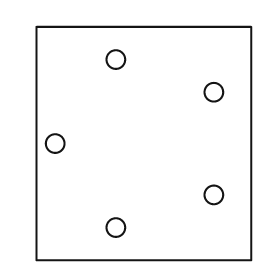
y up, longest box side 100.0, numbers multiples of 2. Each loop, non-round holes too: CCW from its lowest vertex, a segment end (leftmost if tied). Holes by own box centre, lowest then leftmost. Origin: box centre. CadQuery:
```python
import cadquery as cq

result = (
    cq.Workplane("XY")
    .moveTo(-46.0, -50.0)
    .lineTo(46.0, -50.0)
    .lineTo(46.0, 50.0)
    .lineTo(-46.0, 50.0)
    .close()
    .moveTo(-12.0, -36.0)
    .circle(4.0)
    .moveTo(30.0, -22.0)
    .circle(4.0)
    .moveTo(-38.0, 0.0)
    .circle(4.0)
    .moveTo(30.0, 22.0)
    .circle(4.0)
    .moveTo(-12.0, 36.0)
    .circle(4.0)
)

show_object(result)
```